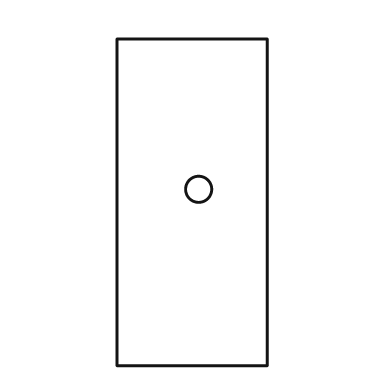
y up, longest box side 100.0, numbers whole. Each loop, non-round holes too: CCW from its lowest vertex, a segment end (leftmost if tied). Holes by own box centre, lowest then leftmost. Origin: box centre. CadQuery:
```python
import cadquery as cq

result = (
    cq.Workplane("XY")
    .moveTo(-23.0, -50.0)
    .lineTo(23.0, -50.0)
    .lineTo(23.0, 50.0)
    .lineTo(-23.0, 50.0)
    .close()
    .moveTo(2.0, 4.0)
    .circle(4.0)
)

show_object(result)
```